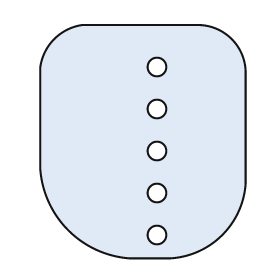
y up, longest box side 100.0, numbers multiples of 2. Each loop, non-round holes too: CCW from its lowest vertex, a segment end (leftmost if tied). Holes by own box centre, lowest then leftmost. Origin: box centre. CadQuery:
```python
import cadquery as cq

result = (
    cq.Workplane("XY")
    .moveTo(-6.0, -50.0)
    .lineTo(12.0, -50.0)
    .threePointArc((34.0, -40.0), (44.0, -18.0))
    .lineTo(44.0, 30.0)
    .threePointArc((38.0, 44.0), (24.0, 50.0))
    .lineTo(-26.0, 50.0)
    .threePointArc((-38.0, 44.0), (-44.0, 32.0))
    .lineTo(-44.0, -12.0)
    .threePointArc((-32.0, -38.0), (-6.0, -50.0))
    .close()
    .moveTo(6.0, -40.0)
    .circle(4.0)
    .moveTo(6.0, -22.0)
    .circle(4.0)
    .moveTo(6.0, -4.0)
    .circle(4.0)
    .moveTo(6.0, 14.0)
    .circle(4.0)
    .moveTo(6.0, 32.0)
    .circle(4.0)
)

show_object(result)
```